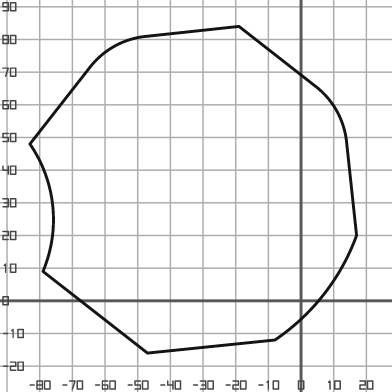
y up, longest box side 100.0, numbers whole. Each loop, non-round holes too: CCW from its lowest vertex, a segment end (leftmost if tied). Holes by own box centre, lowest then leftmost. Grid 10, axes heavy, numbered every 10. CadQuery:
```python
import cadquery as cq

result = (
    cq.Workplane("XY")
    .moveTo(-47.0, -16.0)
    .lineTo(-8.0, -12.0)
    .threePointArc((7.0, 2.0), (17.0, 20.0))
    .lineTo(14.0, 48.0)
    .threePointArc((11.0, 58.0), (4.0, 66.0))
    .lineTo(-19.0, 84.0)
    .lineTo(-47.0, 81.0)
    .threePointArc((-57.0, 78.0), (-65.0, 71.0))
    .lineTo(-83.0, 48.0)
    .threePointArc((-76.0, 29.0), (-79.0, 9.0))
    .close()
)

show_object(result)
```